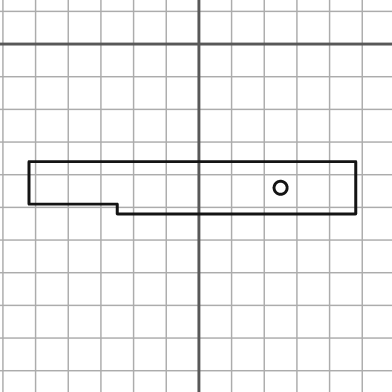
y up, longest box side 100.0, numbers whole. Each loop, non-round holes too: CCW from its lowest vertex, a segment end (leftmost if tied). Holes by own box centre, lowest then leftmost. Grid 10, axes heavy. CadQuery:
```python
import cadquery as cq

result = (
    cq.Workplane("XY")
    .moveTo(-25.0, -52.0)
    .lineTo(48.0, -52.0)
    .lineTo(48.0, -36.0)
    .lineTo(-52.0, -36.0)
    .lineTo(-52.0, -49.0)
    .lineTo(-25.0, -49.0)
    .close()
    .moveTo(25.0, -44.0)
    .circle(2.0)
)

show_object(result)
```